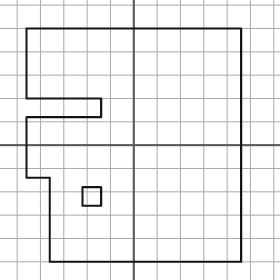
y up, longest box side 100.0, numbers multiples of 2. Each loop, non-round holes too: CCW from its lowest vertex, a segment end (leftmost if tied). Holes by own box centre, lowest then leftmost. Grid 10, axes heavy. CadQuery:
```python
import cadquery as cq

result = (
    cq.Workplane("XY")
    .moveTo(-36.0, -50.0)
    .lineTo(46.0, -50.0)
    .lineTo(46.0, 50.0)
    .lineTo(-46.0, 50.0)
    .lineTo(-46.0, 20.0)
    .lineTo(-14.0, 20.0)
    .lineTo(-14.0, 12.0)
    .lineTo(-46.0, 12.0)
    .lineTo(-46.0, -14.0)
    .lineTo(-36.0, -14.0)
    .close()
    .moveTo(-22.0, -26.0)
    .lineTo(-14.0, -26.0)
    .lineTo(-14.0, -18.0)
    .lineTo(-22.0, -18.0)
    .close()
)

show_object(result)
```